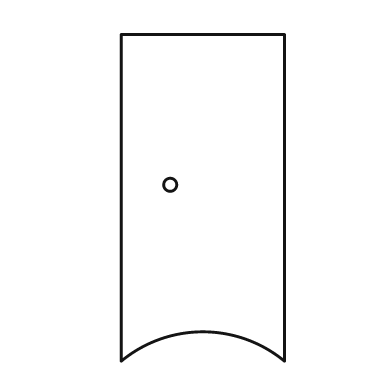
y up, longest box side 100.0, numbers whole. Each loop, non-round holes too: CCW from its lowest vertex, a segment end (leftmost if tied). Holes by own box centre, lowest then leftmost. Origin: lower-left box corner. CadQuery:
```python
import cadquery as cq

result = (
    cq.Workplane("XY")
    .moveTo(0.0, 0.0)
    .threePointArc((25.0, 9.0), (50.0, 0.0))
    .lineTo(50.0, 100.0)
    .lineTo(0.0, 100.0)
    .close()
    .moveTo(15.0, 54.0)
    .circle(2.0)
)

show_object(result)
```